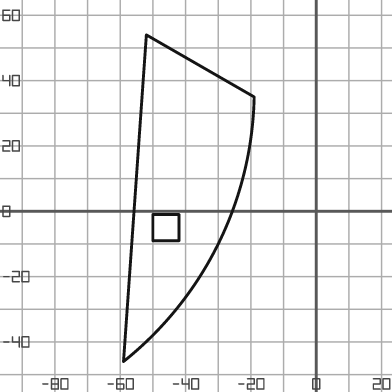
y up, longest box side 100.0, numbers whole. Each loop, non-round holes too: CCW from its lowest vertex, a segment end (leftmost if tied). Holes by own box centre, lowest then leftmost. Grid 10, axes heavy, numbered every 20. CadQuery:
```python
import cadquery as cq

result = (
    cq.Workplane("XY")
    .moveTo(-59.0, -46.0)
    .threePointArc((-30.0, -10.0), (-19.0, 35.0))
    .lineTo(-52.0, 54.0)
    .close()
    .moveTo(-50.0, -9.0)
    .lineTo(-42.0, -9.0)
    .lineTo(-42.0, -1.0)
    .lineTo(-50.0, -1.0)
    .close()
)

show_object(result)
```